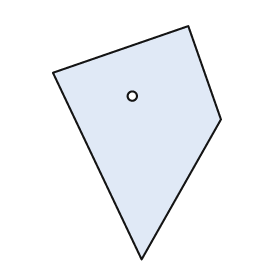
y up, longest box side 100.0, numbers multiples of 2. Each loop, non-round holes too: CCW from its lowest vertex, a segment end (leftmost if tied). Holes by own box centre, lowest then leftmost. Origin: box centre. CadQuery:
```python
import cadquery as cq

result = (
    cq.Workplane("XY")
    .moveTo(2.0, -50.0)
    .lineTo(36.0, 10.0)
    .lineTo(22.0, 50.0)
    .lineTo(-36.0, 30.0)
    .close()
    .moveTo(-2.0, 20.0)
    .circle(2.0)
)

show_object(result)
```